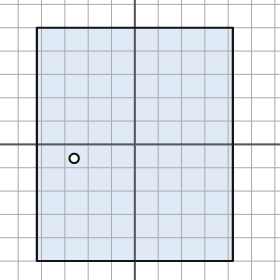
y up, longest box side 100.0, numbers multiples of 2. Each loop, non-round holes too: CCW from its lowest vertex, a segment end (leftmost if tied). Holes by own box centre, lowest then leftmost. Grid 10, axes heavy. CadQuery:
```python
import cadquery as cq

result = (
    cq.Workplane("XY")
    .moveTo(-42.0, -50.0)
    .lineTo(42.0, -50.0)
    .lineTo(42.0, 50.0)
    .lineTo(-42.0, 50.0)
    .close()
    .moveTo(-26.0, -6.0)
    .circle(2.0)
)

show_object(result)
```